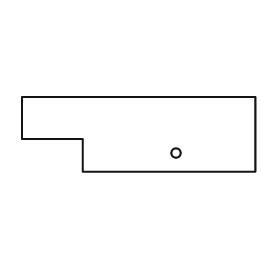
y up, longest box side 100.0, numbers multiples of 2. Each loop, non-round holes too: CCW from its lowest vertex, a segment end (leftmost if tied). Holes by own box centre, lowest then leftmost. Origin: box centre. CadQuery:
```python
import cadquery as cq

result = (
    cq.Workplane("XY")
    .moveTo(-24.0, -16.0)
    .lineTo(50.0, -16.0)
    .lineTo(50.0, 16.0)
    .lineTo(-50.0, 16.0)
    .lineTo(-50.0, -2.0)
    .lineTo(-24.0, -2.0)
    .close()
    .moveTo(16.0, -8.0)
    .circle(2.0)
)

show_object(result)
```